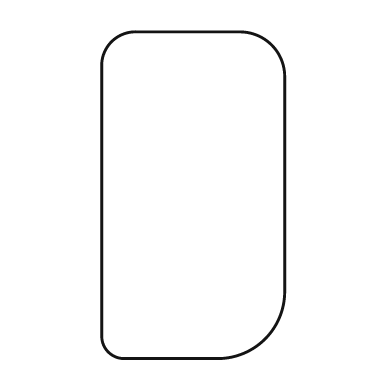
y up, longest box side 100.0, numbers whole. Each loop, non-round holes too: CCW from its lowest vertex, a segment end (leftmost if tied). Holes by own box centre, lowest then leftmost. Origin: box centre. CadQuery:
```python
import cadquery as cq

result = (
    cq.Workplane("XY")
    .moveTo(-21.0, -50.0)
    .lineTo(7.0, -50.0)
    .threePointArc((22.0, -44.0), (28.0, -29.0))
    .lineTo(28.0, 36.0)
    .threePointArc((24.0, 46.0), (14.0, 50.0))
    .lineTo(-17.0, 50.0)
    .threePointArc((-25.0, 47.0), (-28.0, 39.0))
    .lineTo(-28.0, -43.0)
    .threePointArc((-26.0, -48.0), (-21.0, -50.0))
    .close()
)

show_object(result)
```